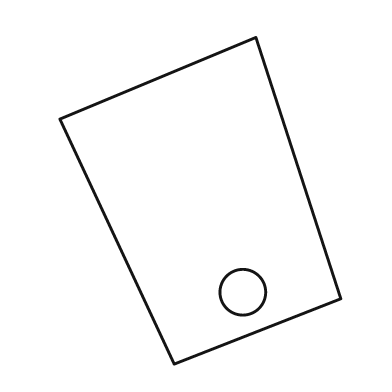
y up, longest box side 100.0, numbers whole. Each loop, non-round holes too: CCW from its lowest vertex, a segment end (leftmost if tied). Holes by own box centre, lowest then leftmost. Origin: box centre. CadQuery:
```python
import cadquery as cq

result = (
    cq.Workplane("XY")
    .moveTo(-8.0, -50.0)
    .lineTo(43.0, -30.0)
    .lineTo(17.0, 50.0)
    .lineTo(-43.0, 25.0)
    .close()
    .moveTo(13.0, -28.0)
    .circle(7.0)
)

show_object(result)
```